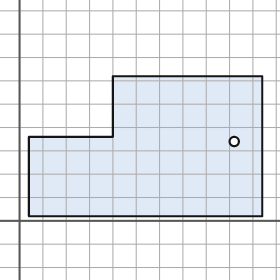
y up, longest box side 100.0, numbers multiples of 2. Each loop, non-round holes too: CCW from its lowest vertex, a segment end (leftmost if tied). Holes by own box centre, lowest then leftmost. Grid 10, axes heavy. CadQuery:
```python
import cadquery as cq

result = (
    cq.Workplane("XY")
    .moveTo(4.0, 2.0)
    .lineTo(104.0, 2.0)
    .lineTo(104.0, 62.0)
    .lineTo(40.0, 62.0)
    .lineTo(40.0, 36.0)
    .lineTo(4.0, 36.0)
    .close()
    .moveTo(92.0, 34.0)
    .circle(2.0)
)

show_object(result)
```